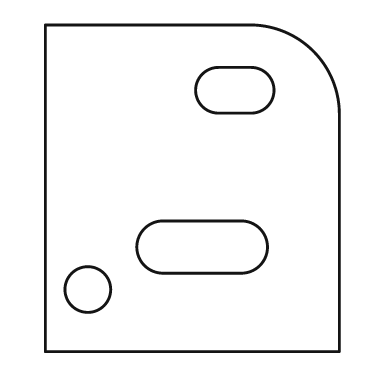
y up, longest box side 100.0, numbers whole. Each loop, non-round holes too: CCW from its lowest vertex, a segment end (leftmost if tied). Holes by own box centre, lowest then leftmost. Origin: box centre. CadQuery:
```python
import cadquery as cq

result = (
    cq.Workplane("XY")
    .moveTo(-45.0, -50.0)
    .lineTo(45.0, -50.0)
    .lineTo(45.0, 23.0)
    .threePointArc((37.0, 42.0), (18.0, 50.0))
    .lineTo(-45.0, 50.0)
    .close()
    .moveTo(-32.0, -31.0)
    .circle(7.0)
    .moveTo(-9.0, -26.0)
    .lineTo(15.0, -26.0)
    .threePointArc((23.0, -18.0), (15.0, -10.0))
    .lineTo(-9.0, -10.0)
    .threePointArc((-17.0, -18.0), (-9.0, -26.0))
    .close()
    .moveTo(8.0, 23.0)
    .lineTo(18.0, 23.0)
    .threePointArc((25.0, 30.0), (18.0, 37.0))
    .lineTo(8.0, 37.0)
    .threePointArc((1.0, 30.0), (8.0, 23.0))
    .close()
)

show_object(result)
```